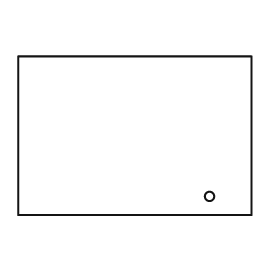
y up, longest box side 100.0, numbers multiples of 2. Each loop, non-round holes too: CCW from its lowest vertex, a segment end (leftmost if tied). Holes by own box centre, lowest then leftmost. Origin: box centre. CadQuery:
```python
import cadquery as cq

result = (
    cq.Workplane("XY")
    .moveTo(-50.0, -34.0)
    .lineTo(50.0, -34.0)
    .lineTo(50.0, 34.0)
    .lineTo(-50.0, 34.0)
    .close()
    .moveTo(32.0, -26.0)
    .circle(2.0)
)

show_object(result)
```